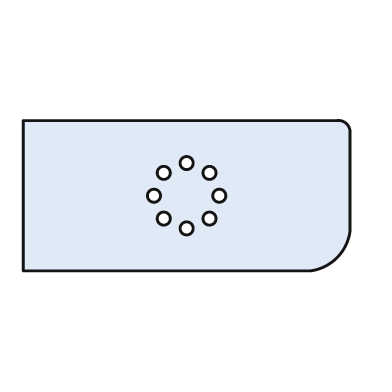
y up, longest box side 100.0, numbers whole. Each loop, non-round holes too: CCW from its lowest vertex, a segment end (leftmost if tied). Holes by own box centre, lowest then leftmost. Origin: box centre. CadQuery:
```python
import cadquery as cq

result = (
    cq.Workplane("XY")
    .moveTo(-50.0, -23.0)
    .lineTo(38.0, -23.0)
    .threePointArc((46.0, -19.0), (50.0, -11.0))
    .lineTo(50.0, 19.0)
    .threePointArc((49.0, 22.0), (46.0, 23.0))
    .lineTo(-50.0, 23.0)
    .close()
    .moveTo(0.0, -10.0)
    .circle(2.0)
    .moveTo(-7.0, -7.0)
    .circle(2.0)
    .moveTo(7.0, -7.0)
    .circle(2.0)
    .moveTo(-10.0, 0.0)
    .circle(2.0)
    .moveTo(10.0, 0.0)
    .circle(2.0)
    .moveTo(-7.0, 7.0)
    .circle(2.0)
    .moveTo(7.0, 7.0)
    .circle(2.0)
    .moveTo(0.0, 10.0)
    .circle(2.0)
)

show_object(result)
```